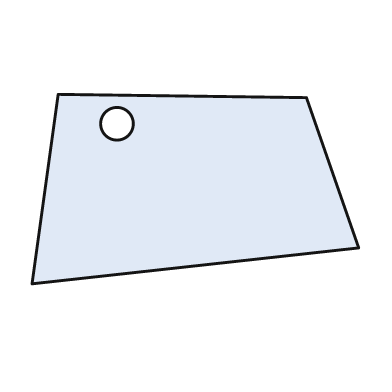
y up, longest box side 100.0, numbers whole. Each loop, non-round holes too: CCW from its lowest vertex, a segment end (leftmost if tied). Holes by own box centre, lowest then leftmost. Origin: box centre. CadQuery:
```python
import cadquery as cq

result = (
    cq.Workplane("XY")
    .moveTo(-50.0, -29.0)
    .lineTo(50.0, -18.0)
    .lineTo(34.0, 28.0)
    .lineTo(-42.0, 29.0)
    .close()
    .moveTo(-24.0, 20.0)
    .circle(5.0)
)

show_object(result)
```